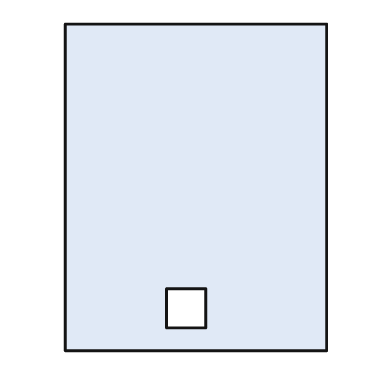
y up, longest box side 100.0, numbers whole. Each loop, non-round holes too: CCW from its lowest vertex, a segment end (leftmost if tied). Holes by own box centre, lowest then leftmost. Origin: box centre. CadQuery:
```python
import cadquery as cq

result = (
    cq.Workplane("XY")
    .moveTo(-40.0, -50.0)
    .lineTo(40.0, -50.0)
    .lineTo(40.0, 50.0)
    .lineTo(-40.0, 50.0)
    .close()
    .moveTo(-9.0, -43.0)
    .lineTo(3.0, -43.0)
    .lineTo(3.0, -31.0)
    .lineTo(-9.0, -31.0)
    .close()
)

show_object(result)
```